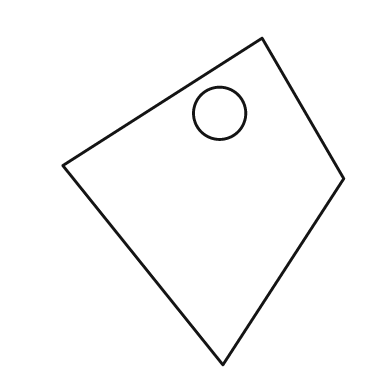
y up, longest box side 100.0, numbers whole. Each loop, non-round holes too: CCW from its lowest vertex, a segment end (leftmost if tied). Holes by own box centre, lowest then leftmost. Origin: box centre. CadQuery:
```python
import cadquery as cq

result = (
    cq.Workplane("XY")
    .moveTo(6.0, -50.0)
    .lineTo(43.0, 7.0)
    .lineTo(18.0, 50.0)
    .lineTo(-43.0, 11.0)
    .close()
    .moveTo(5.0, 27.0)
    .circle(8.0)
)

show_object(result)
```